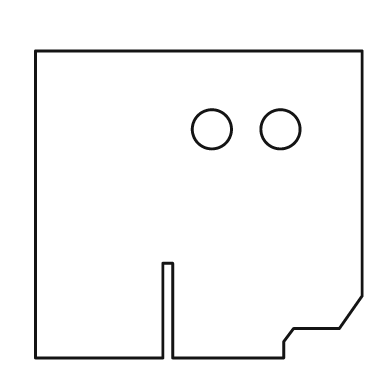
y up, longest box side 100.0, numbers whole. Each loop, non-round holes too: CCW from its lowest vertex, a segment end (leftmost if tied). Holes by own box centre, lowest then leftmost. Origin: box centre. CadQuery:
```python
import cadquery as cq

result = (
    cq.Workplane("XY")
    .moveTo(-50.0, -47.0)
    .lineTo(-11.0, -47.0)
    .lineTo(-11.0, -18.0)
    .lineTo(-8.0, -18.0)
    .lineTo(-8.0, -47.0)
    .lineTo(26.0, -47.0)
    .lineTo(26.0, -42.0)
    .lineTo(29.0, -38.0)
    .lineTo(43.0, -38.0)
    .lineTo(50.0, -28.0)
    .lineTo(50.0, 47.0)
    .lineTo(-50.0, 47.0)
    .close()
    .moveTo(4.0, 23.0)
    .circle(6.0)
    .moveTo(25.0, 23.0)
    .circle(6.0)
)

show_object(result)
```